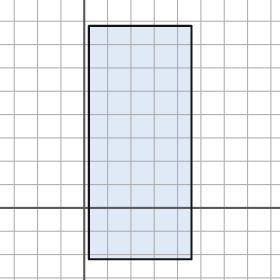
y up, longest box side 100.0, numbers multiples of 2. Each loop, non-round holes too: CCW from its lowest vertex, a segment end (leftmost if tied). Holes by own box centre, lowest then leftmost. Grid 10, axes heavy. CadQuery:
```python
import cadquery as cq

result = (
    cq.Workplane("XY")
    .moveTo(2.0, -22.0)
    .lineTo(46.0, -22.0)
    .lineTo(46.0, 78.0)
    .lineTo(2.0, 78.0)
    .close()
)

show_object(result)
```